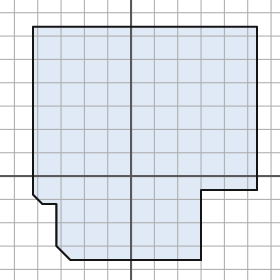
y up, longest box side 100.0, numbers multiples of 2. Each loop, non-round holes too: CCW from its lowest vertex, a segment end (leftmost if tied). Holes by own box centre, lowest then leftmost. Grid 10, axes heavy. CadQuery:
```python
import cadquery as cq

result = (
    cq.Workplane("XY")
    .moveTo(-26.0, -36.0)
    .lineTo(30.0, -36.0)
    .lineTo(30.0, -6.0)
    .lineTo(54.0, -6.0)
    .lineTo(54.0, 64.0)
    .lineTo(-42.0, 64.0)
    .lineTo(-42.0, -8.0)
    .lineTo(-38.0, -12.0)
    .lineTo(-32.0, -12.0)
    .lineTo(-32.0, -30.0)
    .close()
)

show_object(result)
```